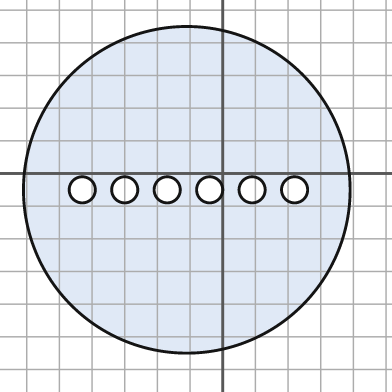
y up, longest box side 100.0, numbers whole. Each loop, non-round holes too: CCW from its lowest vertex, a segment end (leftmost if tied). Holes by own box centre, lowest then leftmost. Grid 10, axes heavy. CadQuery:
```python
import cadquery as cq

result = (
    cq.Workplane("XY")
    .moveTo(-11.0, -5.0)
    .circle(50.0)
    .moveTo(-43.0, -5.0)
    .circle(4.0)
    .moveTo(-30.0, -5.0)
    .circle(4.0)
    .moveTo(-17.0, -5.0)
    .circle(4.0)
    .moveTo(-4.0, -5.0)
    .circle(4.0)
    .moveTo(9.0, -5.0)
    .circle(4.0)
    .moveTo(22.0, -5.0)
    .circle(4.0)
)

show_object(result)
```